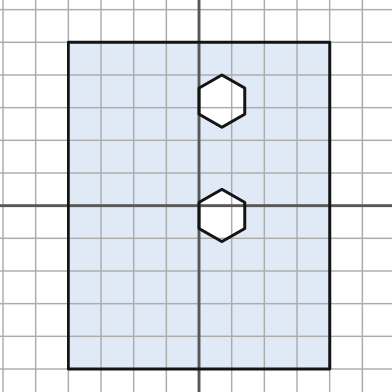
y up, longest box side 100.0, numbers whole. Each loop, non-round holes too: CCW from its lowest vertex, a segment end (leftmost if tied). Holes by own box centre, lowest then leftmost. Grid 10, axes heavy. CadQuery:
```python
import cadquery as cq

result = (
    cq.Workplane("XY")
    .moveTo(-40.0, -50.0)
    .lineTo(40.0, -50.0)
    .lineTo(40.0, 50.0)
    .lineTo(-40.0, 50.0)
    .close()
    .moveTo(7.0, -11.0)
    .lineTo(14.0, -7.0)
    .lineTo(14.0, 1.0)
    .lineTo(7.0, 5.0)
    .lineTo(0.0, 1.0)
    .lineTo(0.0, -7.0)
    .close()
    .moveTo(7.0, 24.0)
    .lineTo(14.0, 28.0)
    .lineTo(14.0, 36.0)
    .lineTo(7.0, 40.0)
    .lineTo(0.0, 36.0)
    .lineTo(0.0, 28.0)
    .close()
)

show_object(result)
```